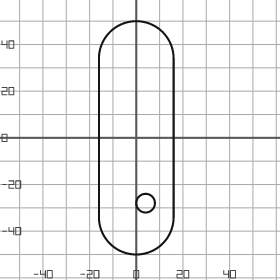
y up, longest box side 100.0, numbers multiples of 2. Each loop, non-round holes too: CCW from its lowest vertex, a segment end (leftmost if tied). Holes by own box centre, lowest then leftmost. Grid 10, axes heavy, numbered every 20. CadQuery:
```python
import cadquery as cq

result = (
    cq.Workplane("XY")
    .moveTo(-16.0, -34.0)
    .threePointArc((0.0, -50.0), (16.0, -34.0))
    .lineTo(16.0, 34.0)
    .threePointArc((0.0, 50.0), (-16.0, 34.0))
    .close()
    .moveTo(4.0, -28.0)
    .circle(4.0)
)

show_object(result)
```